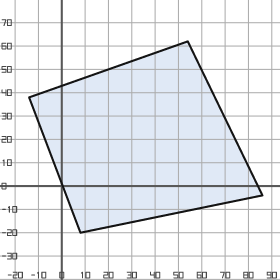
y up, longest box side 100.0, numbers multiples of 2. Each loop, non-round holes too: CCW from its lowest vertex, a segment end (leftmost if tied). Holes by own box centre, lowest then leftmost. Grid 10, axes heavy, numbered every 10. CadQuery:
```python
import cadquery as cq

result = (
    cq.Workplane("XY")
    .moveTo(8.0, -20.0)
    .lineTo(86.0, -4.0)
    .lineTo(54.0, 62.0)
    .lineTo(-14.0, 38.0)
    .close()
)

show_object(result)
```